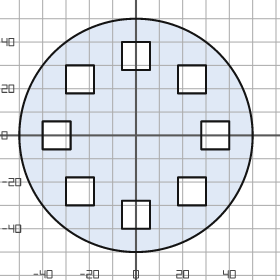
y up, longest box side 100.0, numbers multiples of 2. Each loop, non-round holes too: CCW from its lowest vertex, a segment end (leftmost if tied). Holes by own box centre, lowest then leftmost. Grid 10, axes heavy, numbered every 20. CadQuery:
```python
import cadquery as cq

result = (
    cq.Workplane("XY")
    .moveTo(0.0, 0.0)
    .circle(50.0)
    .moveTo(-6.0, -40.0)
    .lineTo(6.0, -40.0)
    .lineTo(6.0, -28.0)
    .lineTo(-6.0, -28.0)
    .close()
    .moveTo(-30.0, -30.0)
    .lineTo(-18.0, -30.0)
    .lineTo(-18.0, -18.0)
    .lineTo(-30.0, -18.0)
    .close()
    .moveTo(18.0, -30.0)
    .lineTo(30.0, -30.0)
    .lineTo(30.0, -18.0)
    .lineTo(18.0, -18.0)
    .close()
    .moveTo(-40.0, -6.0)
    .lineTo(-28.0, -6.0)
    .lineTo(-28.0, 6.0)
    .lineTo(-40.0, 6.0)
    .close()
    .moveTo(28.0, -6.0)
    .lineTo(40.0, -6.0)
    .lineTo(40.0, 6.0)
    .lineTo(28.0, 6.0)
    .close()
    .moveTo(-30.0, 18.0)
    .lineTo(-18.0, 18.0)
    .lineTo(-18.0, 30.0)
    .lineTo(-30.0, 30.0)
    .close()
    .moveTo(18.0, 18.0)
    .lineTo(30.0, 18.0)
    .lineTo(30.0, 30.0)
    .lineTo(18.0, 30.0)
    .close()
    .moveTo(-6.0, 28.0)
    .lineTo(6.0, 28.0)
    .lineTo(6.0, 40.0)
    .lineTo(-6.0, 40.0)
    .close()
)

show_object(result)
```